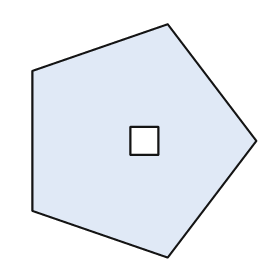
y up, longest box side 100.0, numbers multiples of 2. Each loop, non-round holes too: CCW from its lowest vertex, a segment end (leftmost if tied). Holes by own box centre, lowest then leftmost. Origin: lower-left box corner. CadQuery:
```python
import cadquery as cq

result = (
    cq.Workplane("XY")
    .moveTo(58.0, 0.0)
    .lineTo(96.0, 50.0)
    .lineTo(58.0, 100.0)
    .lineTo(0.0, 80.0)
    .lineTo(0.0, 20.0)
    .close()
    .moveTo(42.0, 44.0)
    .lineTo(54.0, 44.0)
    .lineTo(54.0, 56.0)
    .lineTo(42.0, 56.0)
    .close()
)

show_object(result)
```